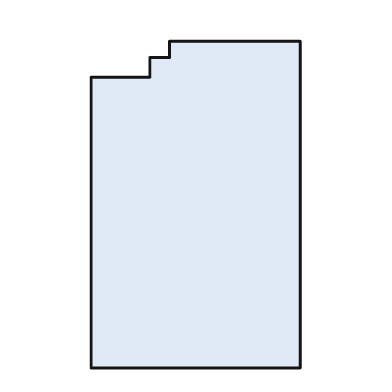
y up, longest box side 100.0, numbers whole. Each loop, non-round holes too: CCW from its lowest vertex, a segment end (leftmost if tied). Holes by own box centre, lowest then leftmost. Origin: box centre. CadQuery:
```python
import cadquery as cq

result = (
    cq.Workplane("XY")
    .moveTo(-32.0, -50.0)
    .lineTo(32.0, -50.0)
    .lineTo(32.0, 50.0)
    .lineTo(-8.0, 50.0)
    .lineTo(-8.0, 45.0)
    .lineTo(-14.0, 45.0)
    .lineTo(-14.0, 39.0)
    .lineTo(-32.0, 39.0)
    .close()
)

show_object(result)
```